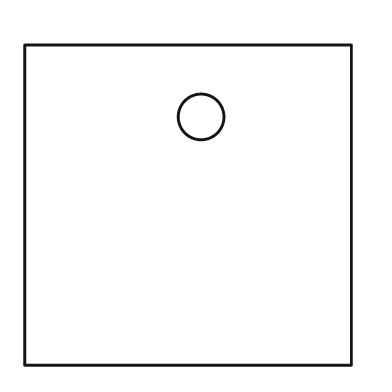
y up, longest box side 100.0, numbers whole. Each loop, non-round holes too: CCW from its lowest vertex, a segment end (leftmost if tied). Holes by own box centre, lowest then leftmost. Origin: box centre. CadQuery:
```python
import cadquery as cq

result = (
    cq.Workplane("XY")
    .moveTo(-50.0, -49.0)
    .lineTo(50.0, -49.0)
    .lineTo(50.0, 49.0)
    .lineTo(-50.0, 49.0)
    .close()
    .moveTo(4.0, 27.0)
    .circle(7.0)
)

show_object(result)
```